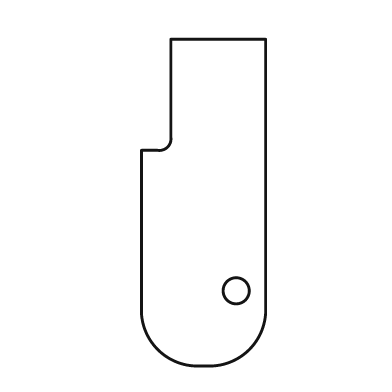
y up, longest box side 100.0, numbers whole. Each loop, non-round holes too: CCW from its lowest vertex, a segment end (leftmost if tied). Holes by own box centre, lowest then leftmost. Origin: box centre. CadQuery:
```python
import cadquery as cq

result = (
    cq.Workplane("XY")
    .moveTo(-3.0, -50.0)
    .lineTo(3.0, -50.0)
    .threePointArc((14.0, -45.0), (19.0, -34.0))
    .lineTo(19.0, 50.0)
    .lineTo(-10.0, 50.0)
    .lineTo(-10.0, 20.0)
    .threePointArc((-11.0, 17.0), (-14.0, 16.0))
    .lineTo(-19.0, 16.0)
    .lineTo(-19.0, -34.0)
    .threePointArc((-14.0, -45.0), (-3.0, -50.0))
    .close()
    .moveTo(10.0, -27.0)
    .circle(4.0)
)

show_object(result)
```